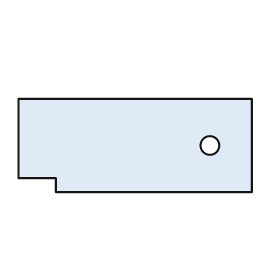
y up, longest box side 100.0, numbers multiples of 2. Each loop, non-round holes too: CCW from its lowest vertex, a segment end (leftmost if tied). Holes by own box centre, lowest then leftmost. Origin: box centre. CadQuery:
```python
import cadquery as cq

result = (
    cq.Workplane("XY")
    .moveTo(-34.0, -20.0)
    .lineTo(50.0, -20.0)
    .lineTo(50.0, 20.0)
    .lineTo(-50.0, 20.0)
    .lineTo(-50.0, -14.0)
    .lineTo(-34.0, -14.0)
    .close()
    .moveTo(32.0, 0.0)
    .circle(4.0)
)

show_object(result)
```